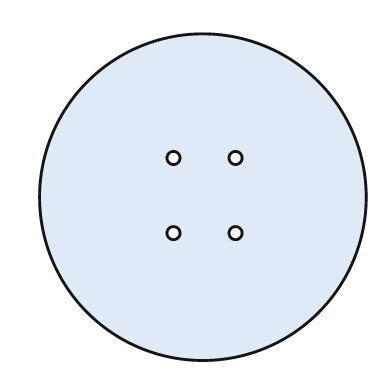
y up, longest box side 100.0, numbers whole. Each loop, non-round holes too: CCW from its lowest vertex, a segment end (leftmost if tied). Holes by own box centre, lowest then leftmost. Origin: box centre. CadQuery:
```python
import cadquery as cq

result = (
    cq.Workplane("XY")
    .moveTo(0.0, 0.0)
    .circle(50.0)
    .moveTo(-9.0, -11.0)
    .circle(2.0)
    .moveTo(10.0, -11.0)
    .circle(2.0)
    .moveTo(-9.0, 12.0)
    .circle(2.0)
    .moveTo(10.0, 12.0)
    .circle(2.0)
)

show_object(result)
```